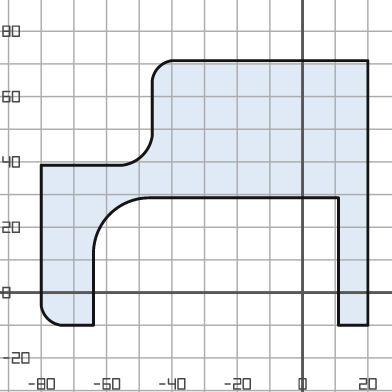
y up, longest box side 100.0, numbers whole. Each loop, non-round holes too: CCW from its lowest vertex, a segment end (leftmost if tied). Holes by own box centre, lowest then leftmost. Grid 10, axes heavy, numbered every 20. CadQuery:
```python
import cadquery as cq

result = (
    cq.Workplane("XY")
    .moveTo(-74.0, -10.0)
    .lineTo(-64.0, -10.0)
    .lineTo(-64.0, 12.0)
    .threePointArc((-59.0, 24.0), (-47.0, 29.0))
    .lineTo(11.0, 29.0)
    .lineTo(11.0, -10.0)
    .lineTo(20.0, -10.0)
    .lineTo(20.0, 71.0)
    .lineTo(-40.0, 71.0)
    .threePointArc((-44.0, 69.0), (-46.0, 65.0))
    .lineTo(-46.0, 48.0)
    .threePointArc((-49.0, 42.0), (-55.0, 39.0))
    .lineTo(-80.0, 39.0)
    .lineTo(-80.0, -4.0)
    .threePointArc((-78.0, -8.0), (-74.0, -10.0))
    .close()
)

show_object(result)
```